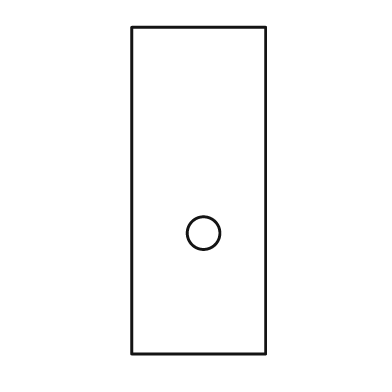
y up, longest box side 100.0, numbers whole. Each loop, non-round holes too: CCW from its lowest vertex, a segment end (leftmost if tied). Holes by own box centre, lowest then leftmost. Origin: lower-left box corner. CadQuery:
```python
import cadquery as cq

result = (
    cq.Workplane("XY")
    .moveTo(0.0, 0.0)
    .lineTo(41.0, 0.0)
    .lineTo(41.0, 100.0)
    .lineTo(0.0, 100.0)
    .close()
    .moveTo(22.0, 37.0)
    .circle(5.0)
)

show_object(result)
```